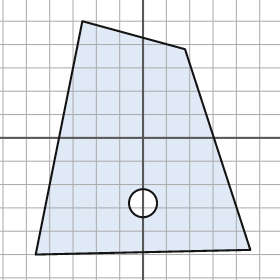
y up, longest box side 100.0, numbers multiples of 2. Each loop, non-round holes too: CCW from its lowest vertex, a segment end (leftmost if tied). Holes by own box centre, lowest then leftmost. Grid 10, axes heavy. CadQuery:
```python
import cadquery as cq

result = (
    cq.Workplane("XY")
    .moveTo(-46.0, -50.0)
    .lineTo(46.0, -48.0)
    .lineTo(18.0, 38.0)
    .lineTo(-26.0, 50.0)
    .close()
    .moveTo(0.0, -28.0)
    .circle(6.0)
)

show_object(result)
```